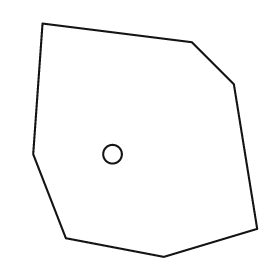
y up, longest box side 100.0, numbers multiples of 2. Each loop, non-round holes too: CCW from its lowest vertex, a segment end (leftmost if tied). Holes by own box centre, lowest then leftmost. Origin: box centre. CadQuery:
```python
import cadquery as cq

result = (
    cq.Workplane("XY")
    .moveTo(8.0, -50.0)
    .lineTo(48.0, -38.0)
    .lineTo(38.0, 24.0)
    .lineTo(20.0, 42.0)
    .lineTo(-44.0, 50.0)
    .lineTo(-48.0, -6.0)
    .lineTo(-34.0, -42.0)
    .close()
    .moveTo(-14.0, -6.0)
    .circle(4.0)
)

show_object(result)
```